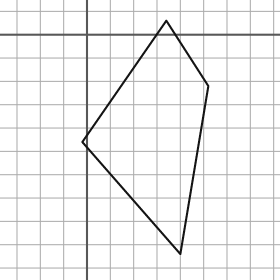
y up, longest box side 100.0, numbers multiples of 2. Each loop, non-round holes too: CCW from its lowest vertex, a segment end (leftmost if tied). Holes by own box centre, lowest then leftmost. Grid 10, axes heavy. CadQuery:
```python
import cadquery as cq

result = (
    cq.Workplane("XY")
    .moveTo(40.0, -94.0)
    .lineTo(52.0, -22.0)
    .lineTo(34.0, 6.0)
    .lineTo(-2.0, -46.0)
    .close()
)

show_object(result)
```